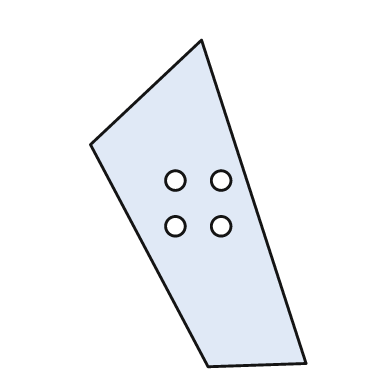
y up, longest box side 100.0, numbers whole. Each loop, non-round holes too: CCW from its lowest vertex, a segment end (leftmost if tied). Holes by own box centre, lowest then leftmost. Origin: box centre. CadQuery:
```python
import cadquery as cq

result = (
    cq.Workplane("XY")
    .moveTo(3.0, -50.0)
    .lineTo(33.0, -49.0)
    .lineTo(1.0, 50.0)
    .lineTo(-33.0, 18.0)
    .close()
    .moveTo(-7.0, -7.0)
    .circle(3.0)
    .moveTo(7.0, -7.0)
    .circle(3.0)
    .moveTo(-7.0, 7.0)
    .circle(3.0)
    .moveTo(7.0, 7.0)
    .circle(3.0)
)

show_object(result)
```